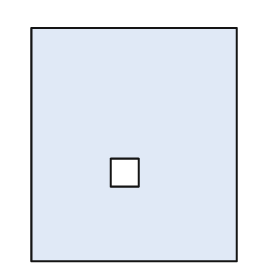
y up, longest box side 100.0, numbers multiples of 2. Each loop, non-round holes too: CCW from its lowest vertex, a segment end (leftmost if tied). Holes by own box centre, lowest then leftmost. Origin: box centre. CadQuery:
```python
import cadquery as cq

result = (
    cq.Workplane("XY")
    .moveTo(-44.0, -50.0)
    .lineTo(44.0, -50.0)
    .lineTo(44.0, 50.0)
    .lineTo(-44.0, 50.0)
    .close()
    .moveTo(-10.0, -18.0)
    .lineTo(2.0, -18.0)
    .lineTo(2.0, -6.0)
    .lineTo(-10.0, -6.0)
    .close()
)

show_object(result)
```